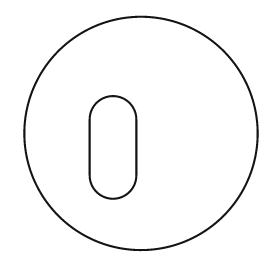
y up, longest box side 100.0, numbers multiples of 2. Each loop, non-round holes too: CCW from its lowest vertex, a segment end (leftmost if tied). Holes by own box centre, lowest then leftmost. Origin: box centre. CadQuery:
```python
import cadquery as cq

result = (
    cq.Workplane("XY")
    .moveTo(0.0, 0.0)
    .circle(50.0)
    .moveTo(-22.0, -18.0)
    .threePointArc((-12.0, -28.0), (-2.0, -18.0))
    .lineTo(-2.0, 6.0)
    .threePointArc((-12.0, 16.0), (-22.0, 6.0))
    .close()
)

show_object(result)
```